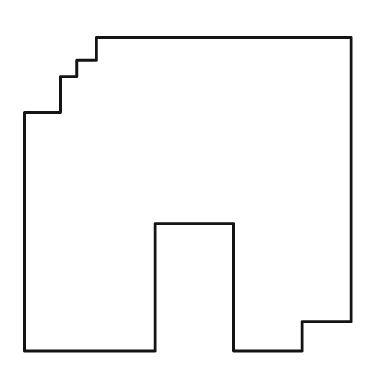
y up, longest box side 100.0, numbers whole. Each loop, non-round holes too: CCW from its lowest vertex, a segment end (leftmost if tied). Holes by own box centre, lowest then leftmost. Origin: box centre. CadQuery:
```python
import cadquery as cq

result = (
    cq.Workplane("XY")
    .moveTo(-50.0, -48.0)
    .lineTo(-10.0, -48.0)
    .lineTo(-10.0, -9.0)
    .lineTo(14.0, -9.0)
    .lineTo(14.0, -48.0)
    .lineTo(35.0, -48.0)
    .lineTo(35.0, -39.0)
    .lineTo(50.0, -39.0)
    .lineTo(50.0, 48.0)
    .lineTo(-28.0, 48.0)
    .lineTo(-28.0, 41.0)
    .lineTo(-34.0, 41.0)
    .lineTo(-34.0, 36.0)
    .lineTo(-39.0, 36.0)
    .lineTo(-39.0, 25.0)
    .lineTo(-50.0, 25.0)
    .close()
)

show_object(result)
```